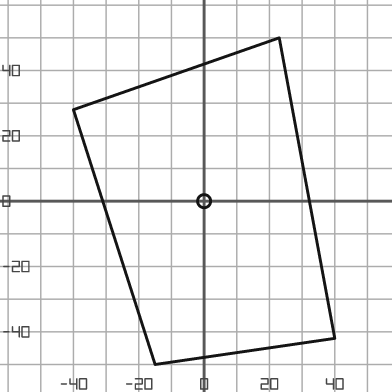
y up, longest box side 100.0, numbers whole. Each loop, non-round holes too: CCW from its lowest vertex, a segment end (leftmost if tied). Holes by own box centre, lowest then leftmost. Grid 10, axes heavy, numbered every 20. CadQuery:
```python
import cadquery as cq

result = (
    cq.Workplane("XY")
    .moveTo(-15.0, -50.0)
    .lineTo(40.0, -42.0)
    .lineTo(23.0, 50.0)
    .lineTo(-40.0, 28.0)
    .close()
    .moveTo(0.0, 0.0)
    .circle(2.0)
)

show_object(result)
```